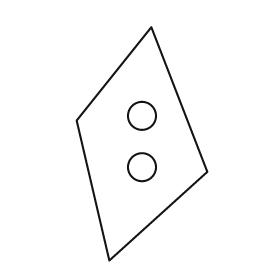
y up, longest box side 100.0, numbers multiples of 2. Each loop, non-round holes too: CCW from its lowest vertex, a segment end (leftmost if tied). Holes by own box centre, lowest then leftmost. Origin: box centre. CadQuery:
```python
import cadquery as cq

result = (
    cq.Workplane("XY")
    .moveTo(-14.0, -50.0)
    .lineTo(28.0, -12.0)
    .lineTo(4.0, 50.0)
    .lineTo(-28.0, 10.0)
    .close()
    .moveTo(0.0, -10.0)
    .circle(6.0)
    .moveTo(0.0, 12.0)
    .circle(6.0)
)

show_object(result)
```